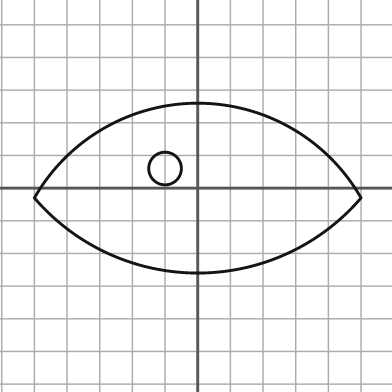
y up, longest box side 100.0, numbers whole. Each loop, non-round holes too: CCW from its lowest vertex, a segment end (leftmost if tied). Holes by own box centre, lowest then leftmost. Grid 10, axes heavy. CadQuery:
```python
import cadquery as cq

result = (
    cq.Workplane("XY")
    .moveTo(-50.0, -3.0)
    .threePointArc((0.0, -26.0), (50.0, -3.0))
    .threePointArc((0.0, 26.0), (-50.0, -3.0))
    .close()
    .moveTo(-10.0, 6.0)
    .circle(5.0)
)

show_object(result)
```